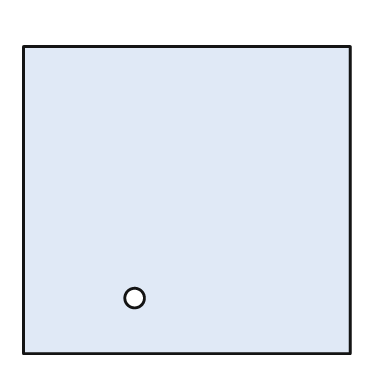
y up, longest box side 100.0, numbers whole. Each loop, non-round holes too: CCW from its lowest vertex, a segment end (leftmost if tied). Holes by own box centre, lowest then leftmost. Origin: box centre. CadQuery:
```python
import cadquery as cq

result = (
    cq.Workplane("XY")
    .moveTo(-50.0, -47.0)
    .lineTo(50.0, -47.0)
    .lineTo(50.0, 47.0)
    .lineTo(-50.0, 47.0)
    .close()
    .moveTo(-16.0, -30.0)
    .circle(3.0)
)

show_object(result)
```